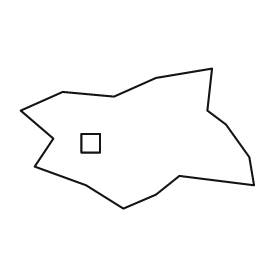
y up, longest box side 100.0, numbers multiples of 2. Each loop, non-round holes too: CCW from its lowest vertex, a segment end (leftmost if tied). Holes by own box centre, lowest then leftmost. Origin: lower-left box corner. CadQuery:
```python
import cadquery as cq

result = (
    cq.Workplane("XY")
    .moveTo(44.0, 0.0)
    .lineTo(58.0, 6.0)
    .lineTo(68.0, 14.0)
    .lineTo(100.0, 10.0)
    .lineTo(98.0, 22.0)
    .lineTo(88.0, 36.0)
    .lineTo(80.0, 42.0)
    .lineTo(82.0, 60.0)
    .lineTo(58.0, 56.0)
    .lineTo(40.0, 48.0)
    .lineTo(18.0, 50.0)
    .lineTo(0.0, 42.0)
    .lineTo(14.0, 30.0)
    .lineTo(6.0, 18.0)
    .lineTo(28.0, 10.0)
    .close()
    .moveTo(26.0, 24.0)
    .lineTo(34.0, 24.0)
    .lineTo(34.0, 32.0)
    .lineTo(26.0, 32.0)
    .close()
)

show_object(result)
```